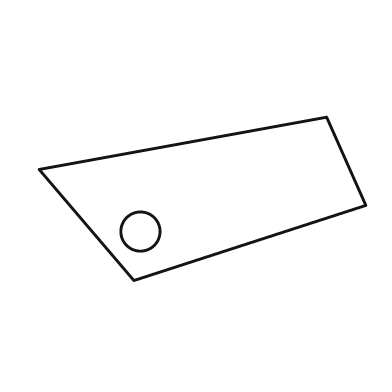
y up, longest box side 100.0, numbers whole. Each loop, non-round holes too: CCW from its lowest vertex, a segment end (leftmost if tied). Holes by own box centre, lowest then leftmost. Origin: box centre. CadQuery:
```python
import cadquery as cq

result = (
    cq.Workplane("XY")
    .moveTo(-21.0, -25.0)
    .lineTo(50.0, -2.0)
    .lineTo(38.0, 25.0)
    .lineTo(-50.0, 9.0)
    .close()
    .moveTo(-19.0, -10.0)
    .circle(6.0)
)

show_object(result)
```